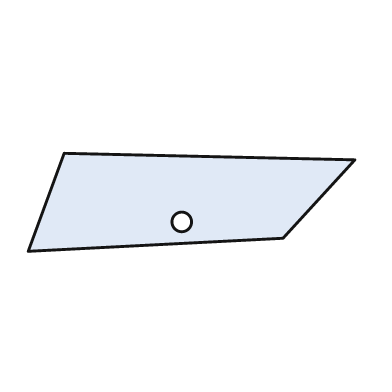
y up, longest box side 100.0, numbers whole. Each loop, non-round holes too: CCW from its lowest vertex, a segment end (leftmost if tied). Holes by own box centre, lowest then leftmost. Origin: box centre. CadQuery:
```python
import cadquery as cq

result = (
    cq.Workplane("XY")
    .moveTo(-50.0, -15.0)
    .lineTo(28.0, -11.0)
    .lineTo(50.0, 13.0)
    .lineTo(-39.0, 15.0)
    .close()
    .moveTo(-3.0, -6.0)
    .circle(3.0)
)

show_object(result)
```